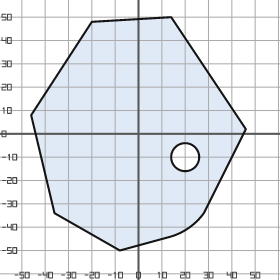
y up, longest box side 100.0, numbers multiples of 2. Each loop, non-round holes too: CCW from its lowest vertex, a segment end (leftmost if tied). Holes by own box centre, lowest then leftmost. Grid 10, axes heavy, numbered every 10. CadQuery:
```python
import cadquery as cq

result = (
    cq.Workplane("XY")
    .moveTo(-8.0, -50.0)
    .lineTo(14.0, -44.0)
    .threePointArc((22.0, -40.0), (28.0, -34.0))
    .lineTo(46.0, 2.0)
    .lineTo(14.0, 50.0)
    .lineTo(-20.0, 48.0)
    .lineTo(-46.0, 8.0)
    .lineTo(-36.0, -34.0)
    .close()
    .moveTo(20.0, -10.0)
    .circle(6.0)
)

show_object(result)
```